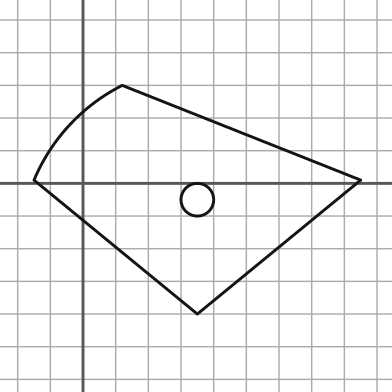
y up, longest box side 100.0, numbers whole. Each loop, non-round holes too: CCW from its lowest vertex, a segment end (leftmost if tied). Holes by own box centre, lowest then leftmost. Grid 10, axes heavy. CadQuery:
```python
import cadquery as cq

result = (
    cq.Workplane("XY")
    .moveTo(35.0, -40.0)
    .lineTo(85.0, 1.0)
    .lineTo(12.0, 30.0)
    .threePointArc((-4.0, 18.0), (-15.0, 1.0))
    .close()
    .moveTo(35.0, -5.0)
    .circle(5.0)
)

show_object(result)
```